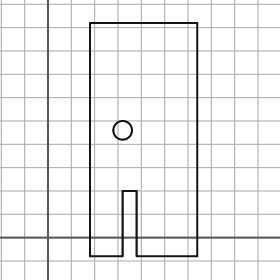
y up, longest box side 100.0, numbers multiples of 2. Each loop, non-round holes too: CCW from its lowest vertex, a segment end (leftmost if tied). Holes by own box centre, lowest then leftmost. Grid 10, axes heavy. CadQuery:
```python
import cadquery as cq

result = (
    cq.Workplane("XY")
    .moveTo(18.0, -8.0)
    .lineTo(32.0, -8.0)
    .lineTo(32.0, 20.0)
    .lineTo(38.0, 20.0)
    .lineTo(38.0, -8.0)
    .lineTo(64.0, -8.0)
    .lineTo(64.0, 92.0)
    .lineTo(18.0, 92.0)
    .close()
    .moveTo(32.0, 46.0)
    .circle(4.0)
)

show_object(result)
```